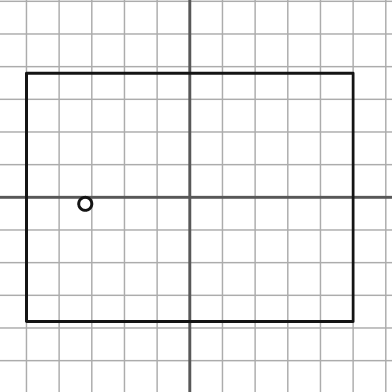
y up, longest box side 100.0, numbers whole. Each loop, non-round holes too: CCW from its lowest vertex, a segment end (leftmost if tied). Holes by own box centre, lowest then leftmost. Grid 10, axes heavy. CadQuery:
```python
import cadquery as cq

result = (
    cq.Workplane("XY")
    .moveTo(-50.0, -38.0)
    .lineTo(50.0, -38.0)
    .lineTo(50.0, 38.0)
    .lineTo(-50.0, 38.0)
    .close()
    .moveTo(-32.0, -2.0)
    .circle(2.0)
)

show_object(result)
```